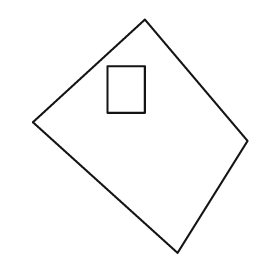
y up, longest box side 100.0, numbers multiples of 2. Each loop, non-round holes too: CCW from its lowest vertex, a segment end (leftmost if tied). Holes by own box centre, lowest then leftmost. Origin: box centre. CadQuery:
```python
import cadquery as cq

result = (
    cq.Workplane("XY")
    .moveTo(16.0, -50.0)
    .lineTo(46.0, -2.0)
    .lineTo(2.0, 50.0)
    .lineTo(-46.0, 6.0)
    .close()
    .moveTo(-14.0, 10.0)
    .lineTo(2.0, 10.0)
    .lineTo(2.0, 30.0)
    .lineTo(-14.0, 30.0)
    .close()
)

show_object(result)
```